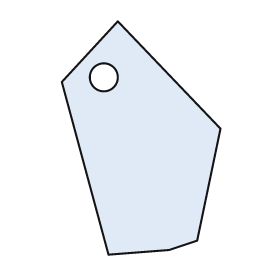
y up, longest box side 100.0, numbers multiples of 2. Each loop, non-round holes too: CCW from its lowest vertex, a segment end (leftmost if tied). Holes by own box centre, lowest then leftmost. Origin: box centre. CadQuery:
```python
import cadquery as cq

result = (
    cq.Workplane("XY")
    .moveTo(-14.0, -50.0)
    .lineTo(12.0, -48.0)
    .lineTo(24.0, -44.0)
    .lineTo(34.0, 4.0)
    .lineTo(-10.0, 50.0)
    .lineTo(-34.0, 24.0)
    .close()
    .moveTo(-16.0, 26.0)
    .circle(6.0)
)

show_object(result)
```